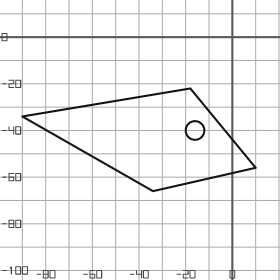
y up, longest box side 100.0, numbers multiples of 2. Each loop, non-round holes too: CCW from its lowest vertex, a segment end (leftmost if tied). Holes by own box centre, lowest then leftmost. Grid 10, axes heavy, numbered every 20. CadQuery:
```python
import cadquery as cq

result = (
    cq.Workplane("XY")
    .moveTo(-34.0, -66.0)
    .lineTo(10.0, -56.0)
    .lineTo(-18.0, -22.0)
    .lineTo(-90.0, -34.0)
    .close()
    .moveTo(-16.0, -40.0)
    .circle(4.0)
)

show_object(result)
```